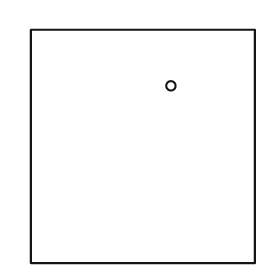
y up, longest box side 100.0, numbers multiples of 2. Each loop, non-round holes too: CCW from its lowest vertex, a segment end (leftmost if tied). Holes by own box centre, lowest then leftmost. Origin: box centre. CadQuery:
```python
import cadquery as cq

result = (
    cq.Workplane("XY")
    .moveTo(-48.0, -50.0)
    .lineTo(48.0, -50.0)
    .lineTo(48.0, 50.0)
    .lineTo(-48.0, 50.0)
    .close()
    .moveTo(12.0, 26.0)
    .circle(2.0)
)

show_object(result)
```